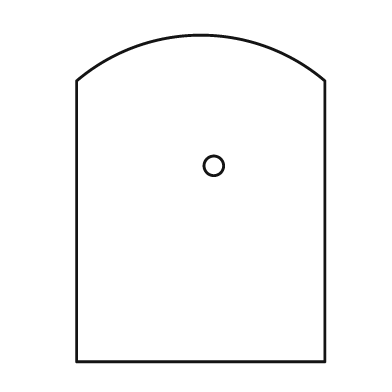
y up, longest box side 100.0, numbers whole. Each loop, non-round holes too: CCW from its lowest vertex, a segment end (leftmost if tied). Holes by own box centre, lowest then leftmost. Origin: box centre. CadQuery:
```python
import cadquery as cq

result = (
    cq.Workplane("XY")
    .moveTo(-38.0, -50.0)
    .lineTo(38.0, -50.0)
    .lineTo(38.0, 36.0)
    .threePointArc((0.0, 50.0), (-38.0, 36.0))
    .close()
    .moveTo(4.0, 10.0)
    .circle(3.0)
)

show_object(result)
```